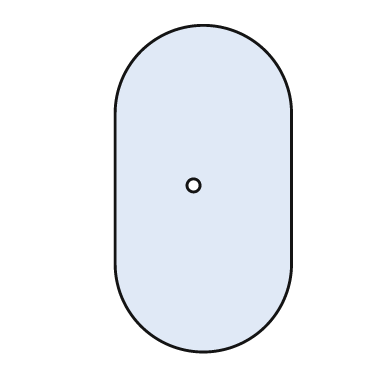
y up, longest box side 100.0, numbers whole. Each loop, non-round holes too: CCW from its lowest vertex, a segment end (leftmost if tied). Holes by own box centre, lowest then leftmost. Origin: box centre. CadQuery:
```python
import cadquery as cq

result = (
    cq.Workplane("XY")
    .moveTo(-27.0, -23.0)
    .threePointArc((0.0, -50.0), (27.0, -23.0))
    .lineTo(27.0, 23.0)
    .threePointArc((0.0, 50.0), (-27.0, 23.0))
    .close()
    .moveTo(-3.0, 1.0)
    .circle(2.0)
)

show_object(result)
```